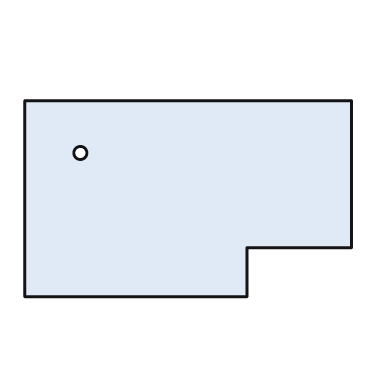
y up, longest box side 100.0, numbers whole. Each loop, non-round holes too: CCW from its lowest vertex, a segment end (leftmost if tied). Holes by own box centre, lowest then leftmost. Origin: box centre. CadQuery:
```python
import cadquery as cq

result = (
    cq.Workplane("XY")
    .moveTo(-50.0, -30.0)
    .lineTo(18.0, -30.0)
    .lineTo(18.0, -15.0)
    .lineTo(50.0, -15.0)
    .lineTo(50.0, 30.0)
    .lineTo(-50.0, 30.0)
    .close()
    .moveTo(-33.0, 14.0)
    .circle(2.0)
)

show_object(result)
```